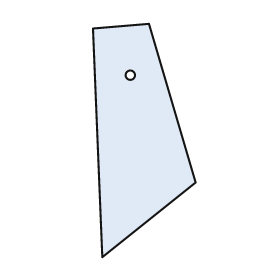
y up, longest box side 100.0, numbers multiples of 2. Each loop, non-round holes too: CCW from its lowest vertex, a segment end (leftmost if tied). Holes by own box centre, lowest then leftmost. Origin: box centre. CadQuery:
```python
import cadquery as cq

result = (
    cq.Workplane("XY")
    .moveTo(-18.0, -50.0)
    .lineTo(22.0, -18.0)
    .lineTo(2.0, 50.0)
    .lineTo(-22.0, 48.0)
    .close()
    .moveTo(-6.0, 28.0)
    .circle(2.0)
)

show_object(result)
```